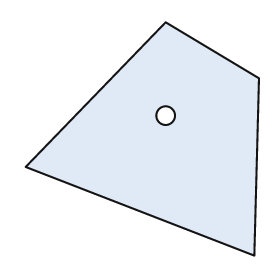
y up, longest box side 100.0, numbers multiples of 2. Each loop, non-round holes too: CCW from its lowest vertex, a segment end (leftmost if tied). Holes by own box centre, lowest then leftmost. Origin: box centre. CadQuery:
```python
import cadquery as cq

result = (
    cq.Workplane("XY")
    .moveTo(48.0, -50.0)
    .lineTo(50.0, 26.0)
    .lineTo(10.0, 50.0)
    .lineTo(-50.0, -12.0)
    .close()
    .moveTo(10.0, 10.0)
    .circle(4.0)
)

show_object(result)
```